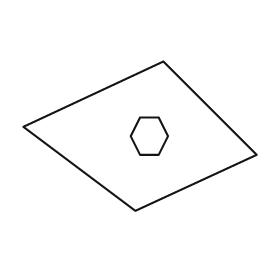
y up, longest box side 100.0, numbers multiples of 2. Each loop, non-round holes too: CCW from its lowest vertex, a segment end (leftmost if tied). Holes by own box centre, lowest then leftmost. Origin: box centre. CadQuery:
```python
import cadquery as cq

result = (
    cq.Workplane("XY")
    .moveTo(-2.0, -32.0)
    .lineTo(50.0, -8.0)
    .lineTo(10.0, 32.0)
    .lineTo(-50.0, 4.0)
    .close()
    .moveTo(0.0, -8.0)
    .lineTo(8.0, -8.0)
    .lineTo(12.0, 0.0)
    .lineTo(8.0, 8.0)
    .lineTo(0.0, 8.0)
    .lineTo(-4.0, 0.0)
    .close()
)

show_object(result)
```